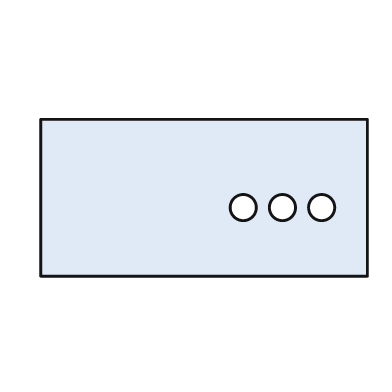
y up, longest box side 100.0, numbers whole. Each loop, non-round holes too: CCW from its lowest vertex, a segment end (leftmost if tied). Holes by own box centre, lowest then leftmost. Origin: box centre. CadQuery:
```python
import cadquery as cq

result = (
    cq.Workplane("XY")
    .moveTo(-50.0, -24.0)
    .lineTo(50.0, -24.0)
    .lineTo(50.0, 24.0)
    .lineTo(-50.0, 24.0)
    .close()
    .moveTo(12.0, -3.0)
    .circle(4.0)
    .moveTo(24.0, -3.0)
    .circle(4.0)
    .moveTo(36.0, -3.0)
    .circle(4.0)
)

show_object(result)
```